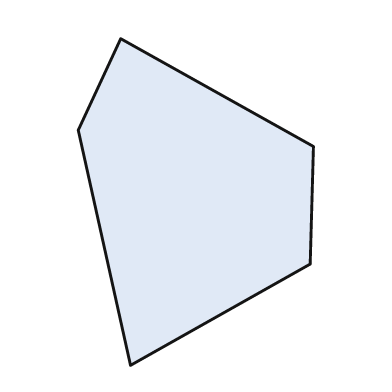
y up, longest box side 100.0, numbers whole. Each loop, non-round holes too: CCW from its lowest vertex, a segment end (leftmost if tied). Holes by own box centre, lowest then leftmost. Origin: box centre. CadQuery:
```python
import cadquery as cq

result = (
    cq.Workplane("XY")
    .moveTo(-20.0, -50.0)
    .lineTo(35.0, -19.0)
    .lineTo(36.0, 17.0)
    .lineTo(-23.0, 50.0)
    .lineTo(-36.0, 22.0)
    .close()
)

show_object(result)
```